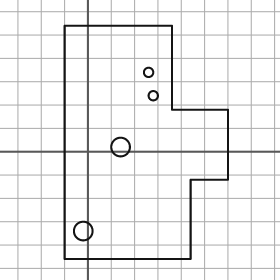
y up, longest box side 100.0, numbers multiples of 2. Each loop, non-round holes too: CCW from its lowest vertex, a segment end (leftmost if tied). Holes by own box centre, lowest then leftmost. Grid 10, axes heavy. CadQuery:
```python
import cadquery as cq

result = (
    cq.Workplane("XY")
    .moveTo(-10.0, -46.0)
    .lineTo(44.0, -46.0)
    .lineTo(44.0, -12.0)
    .lineTo(60.0, -12.0)
    .lineTo(60.0, 18.0)
    .lineTo(36.0, 18.0)
    .lineTo(36.0, 54.0)
    .lineTo(-10.0, 54.0)
    .close()
    .moveTo(-2.0, -34.0)
    .circle(4.0)
    .moveTo(14.0, 2.0)
    .circle(4.0)
    .moveTo(28.0, 24.0)
    .circle(2.0)
    .moveTo(26.0, 34.0)
    .circle(2.0)
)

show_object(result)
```